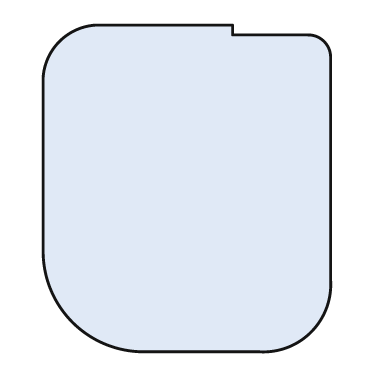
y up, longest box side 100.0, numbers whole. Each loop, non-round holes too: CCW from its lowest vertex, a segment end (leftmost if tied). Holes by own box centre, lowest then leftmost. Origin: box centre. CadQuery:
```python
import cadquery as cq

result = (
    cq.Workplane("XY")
    .moveTo(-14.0, -50.0)
    .lineTo(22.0, -50.0)
    .threePointArc((38.0, -44.0), (44.0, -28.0))
    .lineTo(44.0, 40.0)
    .threePointArc((42.0, 45.0), (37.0, 47.0))
    .lineTo(14.0, 47.0)
    .lineTo(14.0, 50.0)
    .lineTo(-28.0, 50.0)
    .threePointArc((-39.0, 45.0), (-44.0, 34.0))
    .lineTo(-44.0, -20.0)
    .threePointArc((-35.0, -41.0), (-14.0, -50.0))
    .close()
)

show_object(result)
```